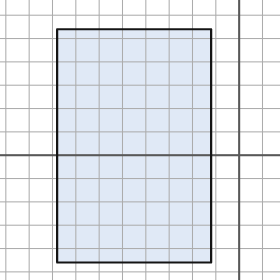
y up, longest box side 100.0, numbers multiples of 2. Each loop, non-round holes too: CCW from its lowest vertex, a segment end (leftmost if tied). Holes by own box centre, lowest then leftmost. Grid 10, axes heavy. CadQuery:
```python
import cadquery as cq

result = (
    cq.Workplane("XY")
    .moveTo(-78.0, -46.0)
    .lineTo(-12.0, -46.0)
    .lineTo(-12.0, 54.0)
    .lineTo(-78.0, 54.0)
    .close()
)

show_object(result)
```